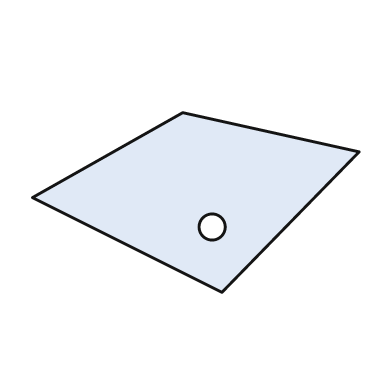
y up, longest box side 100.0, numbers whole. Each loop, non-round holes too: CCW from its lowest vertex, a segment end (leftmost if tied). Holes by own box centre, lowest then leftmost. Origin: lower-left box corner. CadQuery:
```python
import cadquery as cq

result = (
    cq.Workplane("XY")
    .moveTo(58.0, 0.0)
    .lineTo(100.0, 43.0)
    .lineTo(46.0, 55.0)
    .lineTo(0.0, 29.0)
    .close()
    .moveTo(55.0, 20.0)
    .circle(4.0)
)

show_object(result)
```